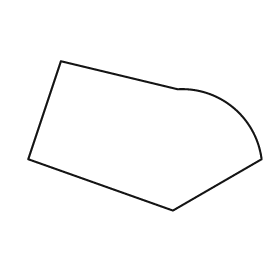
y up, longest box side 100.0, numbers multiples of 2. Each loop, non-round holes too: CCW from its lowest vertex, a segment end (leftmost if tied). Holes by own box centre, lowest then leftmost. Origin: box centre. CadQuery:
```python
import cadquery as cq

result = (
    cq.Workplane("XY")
    .moveTo(12.0, -32.0)
    .lineTo(50.0, -10.0)
    .threePointArc((38.0, 12.0), (14.0, 20.0))
    .lineTo(-36.0, 32.0)
    .lineTo(-50.0, -10.0)
    .close()
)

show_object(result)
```